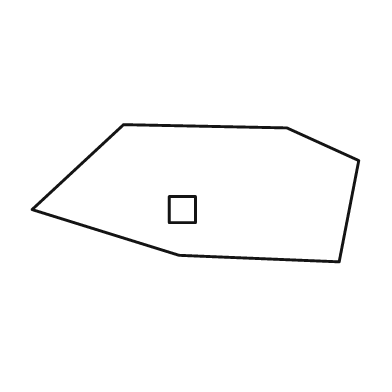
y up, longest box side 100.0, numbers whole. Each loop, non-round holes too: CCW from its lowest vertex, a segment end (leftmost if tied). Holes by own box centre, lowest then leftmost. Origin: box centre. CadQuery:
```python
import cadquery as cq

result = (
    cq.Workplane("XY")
    .moveTo(44.0, -21.0)
    .lineTo(50.0, 10.0)
    .lineTo(28.0, 20.0)
    .lineTo(-22.0, 21.0)
    .lineTo(-50.0, -5.0)
    .lineTo(-5.0, -19.0)
    .close()
    .moveTo(-8.0, -9.0)
    .lineTo(0.0, -9.0)
    .lineTo(0.0, -1.0)
    .lineTo(-8.0, -1.0)
    .close()
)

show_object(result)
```